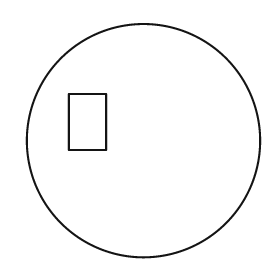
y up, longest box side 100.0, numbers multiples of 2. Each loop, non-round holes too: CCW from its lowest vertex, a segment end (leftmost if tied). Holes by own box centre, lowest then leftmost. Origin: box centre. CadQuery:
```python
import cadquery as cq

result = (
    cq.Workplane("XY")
    .moveTo(0.0, 0.0)
    .circle(50.0)
    .moveTo(-32.0, -4.0)
    .lineTo(-16.0, -4.0)
    .lineTo(-16.0, 20.0)
    .lineTo(-32.0, 20.0)
    .close()
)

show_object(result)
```